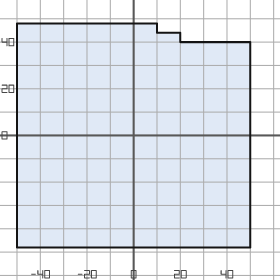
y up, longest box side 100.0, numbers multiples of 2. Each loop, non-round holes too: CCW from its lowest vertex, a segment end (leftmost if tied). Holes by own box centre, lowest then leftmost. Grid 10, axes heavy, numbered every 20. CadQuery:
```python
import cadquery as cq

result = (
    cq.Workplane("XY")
    .moveTo(-50.0, -48.0)
    .lineTo(50.0, -48.0)
    .lineTo(50.0, 40.0)
    .lineTo(20.0, 40.0)
    .lineTo(20.0, 44.0)
    .lineTo(10.0, 44.0)
    .lineTo(10.0, 48.0)
    .lineTo(-50.0, 48.0)
    .close()
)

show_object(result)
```